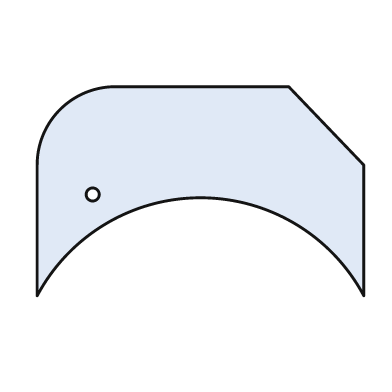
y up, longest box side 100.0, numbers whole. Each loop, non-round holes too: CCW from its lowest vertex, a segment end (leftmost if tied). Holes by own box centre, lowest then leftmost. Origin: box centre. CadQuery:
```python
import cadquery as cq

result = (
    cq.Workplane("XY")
    .moveTo(-50.0, -32.0)
    .threePointArc((0.0, -2.0), (50.0, -32.0))
    .lineTo(50.0, 8.0)
    .lineTo(27.0, 32.0)
    .lineTo(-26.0, 32.0)
    .threePointArc((-43.0, 25.0), (-50.0, 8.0))
    .close()
    .moveTo(-33.0, -1.0)
    .circle(2.0)
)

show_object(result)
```